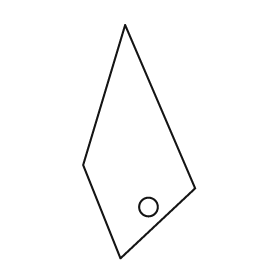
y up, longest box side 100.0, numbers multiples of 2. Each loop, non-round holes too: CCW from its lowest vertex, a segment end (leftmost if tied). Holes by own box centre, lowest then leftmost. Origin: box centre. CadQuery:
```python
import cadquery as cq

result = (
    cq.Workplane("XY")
    .moveTo(-8.0, -50.0)
    .lineTo(24.0, -20.0)
    .lineTo(-6.0, 50.0)
    .lineTo(-24.0, -10.0)
    .close()
    .moveTo(4.0, -28.0)
    .circle(4.0)
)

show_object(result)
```